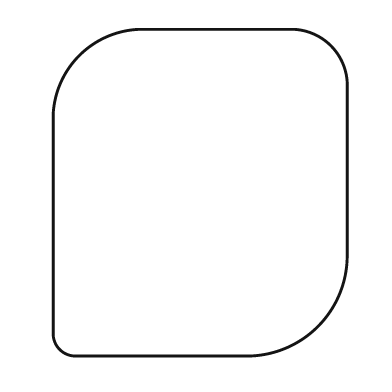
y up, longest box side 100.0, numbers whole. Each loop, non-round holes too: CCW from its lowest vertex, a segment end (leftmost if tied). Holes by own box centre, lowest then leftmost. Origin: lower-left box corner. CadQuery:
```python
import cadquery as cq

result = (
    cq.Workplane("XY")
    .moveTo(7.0, 0.0)
    .lineTo(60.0, 0.0)
    .threePointArc((81.0, 9.0), (90.0, 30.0))
    .lineTo(90.0, 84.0)
    .threePointArc((85.0, 95.0), (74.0, 100.0))
    .lineTo(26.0, 100.0)
    .threePointArc((8.0, 92.0), (0.0, 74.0))
    .lineTo(0.0, 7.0)
    .threePointArc((2.0, 2.0), (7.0, 0.0))
    .close()
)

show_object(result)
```